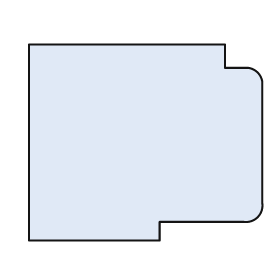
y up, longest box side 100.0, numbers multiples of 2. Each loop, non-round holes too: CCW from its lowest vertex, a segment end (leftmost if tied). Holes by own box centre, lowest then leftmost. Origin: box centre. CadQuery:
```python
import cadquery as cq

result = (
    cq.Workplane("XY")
    .moveTo(-50.0, -42.0)
    .lineTo(6.0, -42.0)
    .lineTo(6.0, -34.0)
    .lineTo(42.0, -34.0)
    .threePointArc((48.0, -32.0), (50.0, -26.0))
    .lineTo(50.0, 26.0)
    .threePointArc((48.0, 30.0), (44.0, 32.0))
    .lineTo(34.0, 32.0)
    .lineTo(34.0, 42.0)
    .lineTo(-50.0, 42.0)
    .close()
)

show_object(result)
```